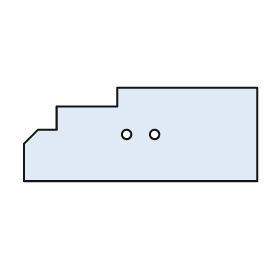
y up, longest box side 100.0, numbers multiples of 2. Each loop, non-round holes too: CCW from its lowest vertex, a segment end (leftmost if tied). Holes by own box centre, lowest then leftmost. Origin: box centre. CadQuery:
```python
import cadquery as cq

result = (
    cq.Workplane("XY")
    .moveTo(-50.0, -20.0)
    .lineTo(50.0, -20.0)
    .lineTo(50.0, 20.0)
    .lineTo(-10.0, 20.0)
    .lineTo(-10.0, 12.0)
    .lineTo(-36.0, 12.0)
    .lineTo(-36.0, 2.0)
    .lineTo(-44.0, 2.0)
    .lineTo(-50.0, -4.0)
    .close()
    .moveTo(-6.0, 0.0)
    .circle(2.0)
    .moveTo(6.0, 0.0)
    .circle(2.0)
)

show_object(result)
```